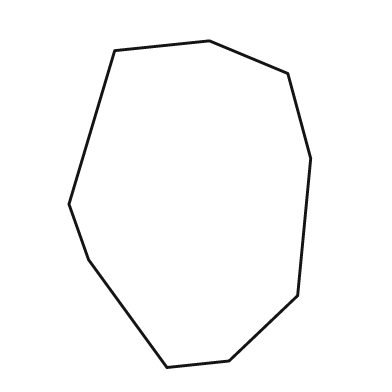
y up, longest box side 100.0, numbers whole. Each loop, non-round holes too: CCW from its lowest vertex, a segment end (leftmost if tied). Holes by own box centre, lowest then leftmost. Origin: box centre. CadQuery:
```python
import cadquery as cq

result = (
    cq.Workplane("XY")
    .moveTo(-7.0, -50.0)
    .lineTo(12.0, -48.0)
    .lineTo(33.0, -28.0)
    .lineTo(37.0, 14.0)
    .lineTo(30.0, 40.0)
    .lineTo(6.0, 50.0)
    .lineTo(-23.0, 47.0)
    .lineTo(-37.0, 0.0)
    .lineTo(-31.0, -17.0)
    .close()
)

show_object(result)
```